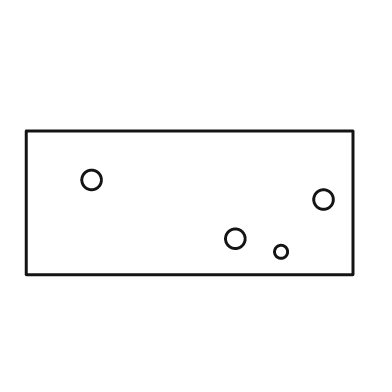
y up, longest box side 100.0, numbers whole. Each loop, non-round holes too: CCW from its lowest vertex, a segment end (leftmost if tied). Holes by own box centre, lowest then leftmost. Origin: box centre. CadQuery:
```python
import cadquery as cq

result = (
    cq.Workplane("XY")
    .moveTo(-50.0, -22.0)
    .lineTo(50.0, -22.0)
    .lineTo(50.0, 22.0)
    .lineTo(-50.0, 22.0)
    .close()
    .moveTo(28.0, -15.0)
    .circle(2.0)
    .moveTo(14.0, -11.0)
    .circle(3.0)
    .moveTo(41.0, 1.0)
    .circle(3.0)
    .moveTo(-30.0, 7.0)
    .circle(3.0)
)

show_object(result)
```